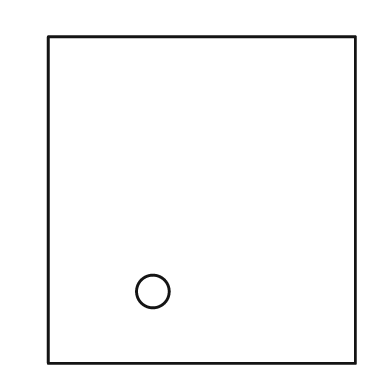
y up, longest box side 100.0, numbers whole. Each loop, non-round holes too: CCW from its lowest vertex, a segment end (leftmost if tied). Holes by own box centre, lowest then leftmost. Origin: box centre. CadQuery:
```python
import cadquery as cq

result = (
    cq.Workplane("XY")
    .moveTo(-47.0, -50.0)
    .lineTo(47.0, -50.0)
    .lineTo(47.0, 50.0)
    .lineTo(-47.0, 50.0)
    .close()
    .moveTo(-15.0, -28.0)
    .circle(5.0)
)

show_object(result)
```